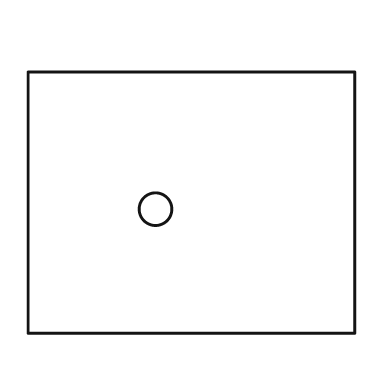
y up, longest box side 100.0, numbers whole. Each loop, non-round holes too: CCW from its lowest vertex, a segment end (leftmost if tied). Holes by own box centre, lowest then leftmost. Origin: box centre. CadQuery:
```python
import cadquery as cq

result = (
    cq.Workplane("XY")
    .moveTo(-50.0, -40.0)
    .lineTo(50.0, -40.0)
    .lineTo(50.0, 40.0)
    .lineTo(-50.0, 40.0)
    .close()
    .moveTo(-11.0, -2.0)
    .circle(5.0)
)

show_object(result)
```